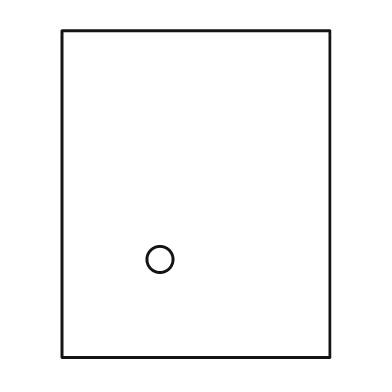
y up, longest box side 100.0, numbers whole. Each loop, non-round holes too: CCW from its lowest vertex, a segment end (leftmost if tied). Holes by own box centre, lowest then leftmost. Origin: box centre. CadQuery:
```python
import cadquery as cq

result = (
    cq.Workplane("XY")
    .moveTo(-41.0, -50.0)
    .lineTo(41.0, -50.0)
    .lineTo(41.0, 50.0)
    .lineTo(-41.0, 50.0)
    .close()
    .moveTo(-11.0, -20.0)
    .circle(4.0)
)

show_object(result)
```